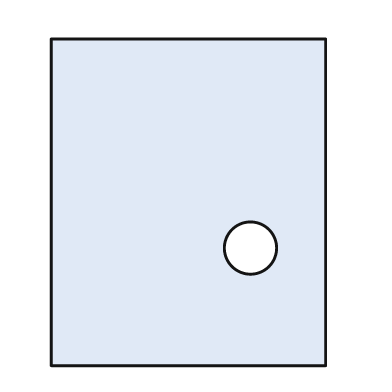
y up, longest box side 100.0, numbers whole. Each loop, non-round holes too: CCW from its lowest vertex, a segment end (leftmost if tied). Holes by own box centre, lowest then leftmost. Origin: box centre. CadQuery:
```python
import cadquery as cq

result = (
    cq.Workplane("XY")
    .moveTo(-42.0, -50.0)
    .lineTo(42.0, -50.0)
    .lineTo(42.0, 50.0)
    .lineTo(-42.0, 50.0)
    .close()
    .moveTo(19.0, -14.0)
    .circle(8.0)
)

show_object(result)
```